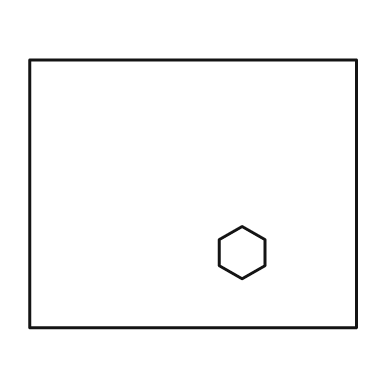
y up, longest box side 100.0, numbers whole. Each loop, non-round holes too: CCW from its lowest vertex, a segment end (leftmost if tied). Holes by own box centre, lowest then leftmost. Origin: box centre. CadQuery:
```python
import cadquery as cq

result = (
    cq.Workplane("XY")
    .moveTo(-50.0, -41.0)
    .lineTo(50.0, -41.0)
    .lineTo(50.0, 41.0)
    .lineTo(-50.0, 41.0)
    .close()
    .moveTo(15.0, -26.0)
    .lineTo(22.0, -22.0)
    .lineTo(22.0, -14.0)
    .lineTo(15.0, -10.0)
    .lineTo(8.0, -14.0)
    .lineTo(8.0, -22.0)
    .close()
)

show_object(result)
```